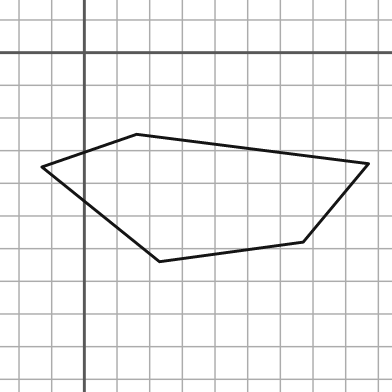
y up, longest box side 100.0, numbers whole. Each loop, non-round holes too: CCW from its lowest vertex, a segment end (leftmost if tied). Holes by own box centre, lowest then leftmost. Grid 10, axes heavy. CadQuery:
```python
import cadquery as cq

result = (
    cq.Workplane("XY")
    .moveTo(23.0, -64.0)
    .lineTo(67.0, -58.0)
    .lineTo(87.0, -34.0)
    .lineTo(16.0, -25.0)
    .lineTo(-13.0, -35.0)
    .close()
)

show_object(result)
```